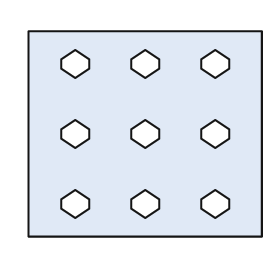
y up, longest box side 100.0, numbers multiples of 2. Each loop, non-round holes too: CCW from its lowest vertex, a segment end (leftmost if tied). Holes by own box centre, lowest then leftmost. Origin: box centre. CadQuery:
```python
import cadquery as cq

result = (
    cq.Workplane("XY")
    .moveTo(-50.0, -44.0)
    .lineTo(50.0, -44.0)
    .lineTo(50.0, 44.0)
    .lineTo(-50.0, 44.0)
    .close()
    .moveTo(-30.0, -36.0)
    .lineTo(-24.0, -32.0)
    .lineTo(-24.0, -28.0)
    .lineTo(-30.0, -24.0)
    .lineTo(-36.0, -28.0)
    .lineTo(-36.0, -32.0)
    .close()
    .moveTo(0.0, -36.0)
    .lineTo(6.0, -32.0)
    .lineTo(6.0, -28.0)
    .lineTo(0.0, -24.0)
    .lineTo(-6.0, -28.0)
    .lineTo(-6.0, -32.0)
    .close()
    .moveTo(30.0, -36.0)
    .lineTo(36.0, -32.0)
    .lineTo(36.0, -28.0)
    .lineTo(30.0, -24.0)
    .lineTo(24.0, -28.0)
    .lineTo(24.0, -32.0)
    .close()
    .moveTo(-30.0, -6.0)
    .lineTo(-24.0, -2.0)
    .lineTo(-24.0, 2.0)
    .lineTo(-30.0, 6.0)
    .lineTo(-36.0, 2.0)
    .lineTo(-36.0, -2.0)
    .close()
    .moveTo(0.0, -6.0)
    .lineTo(6.0, -2.0)
    .lineTo(6.0, 2.0)
    .lineTo(0.0, 6.0)
    .lineTo(-6.0, 2.0)
    .lineTo(-6.0, -2.0)
    .close()
    .moveTo(30.0, -6.0)
    .lineTo(36.0, -2.0)
    .lineTo(36.0, 2.0)
    .lineTo(30.0, 6.0)
    .lineTo(24.0, 2.0)
    .lineTo(24.0, -2.0)
    .close()
    .moveTo(-30.0, 24.0)
    .lineTo(-24.0, 28.0)
    .lineTo(-24.0, 32.0)
    .lineTo(-30.0, 36.0)
    .lineTo(-36.0, 32.0)
    .lineTo(-36.0, 28.0)
    .close()
    .moveTo(0.0, 24.0)
    .lineTo(6.0, 28.0)
    .lineTo(6.0, 32.0)
    .lineTo(0.0, 36.0)
    .lineTo(-6.0, 32.0)
    .lineTo(-6.0, 28.0)
    .close()
    .moveTo(30.0, 24.0)
    .lineTo(36.0, 28.0)
    .lineTo(36.0, 32.0)
    .lineTo(30.0, 36.0)
    .lineTo(24.0, 32.0)
    .lineTo(24.0, 28.0)
    .close()
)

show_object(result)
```